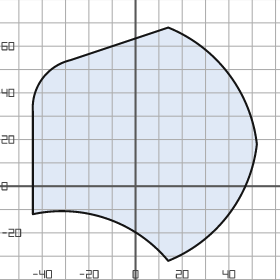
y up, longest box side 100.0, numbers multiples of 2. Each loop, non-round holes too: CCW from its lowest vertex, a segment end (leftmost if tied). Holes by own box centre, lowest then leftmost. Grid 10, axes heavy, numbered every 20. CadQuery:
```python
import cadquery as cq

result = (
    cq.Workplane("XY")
    .moveTo(14.0, -32.0)
    .threePointArc((40.0, -12.0), (52.0, 18.0))
    .threePointArc((40.0, 48.0), (14.0, 68.0))
    .lineTo(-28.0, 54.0)
    .threePointArc((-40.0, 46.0), (-44.0, 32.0))
    .lineTo(-44.0, -12.0)
    .threePointArc((-12.0, -14.0), (14.0, -32.0))
    .close()
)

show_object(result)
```